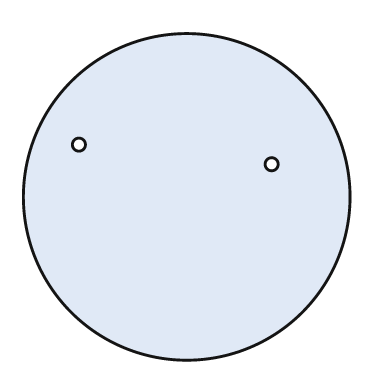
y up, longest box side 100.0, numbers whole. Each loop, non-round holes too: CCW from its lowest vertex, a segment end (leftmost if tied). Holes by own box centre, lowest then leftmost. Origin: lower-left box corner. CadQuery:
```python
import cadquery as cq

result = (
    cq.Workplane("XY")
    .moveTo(50.0, 50.0)
    .circle(50.0)
    .moveTo(76.0, 60.0)
    .circle(2.0)
    .moveTo(17.0, 66.0)
    .circle(2.0)
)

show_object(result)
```